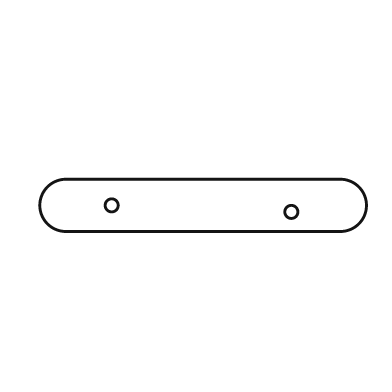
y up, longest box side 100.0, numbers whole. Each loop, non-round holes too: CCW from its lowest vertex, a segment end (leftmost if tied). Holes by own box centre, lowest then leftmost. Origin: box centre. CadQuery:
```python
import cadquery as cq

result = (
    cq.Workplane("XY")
    .moveTo(-42.0, -8.0)
    .lineTo(42.0, -8.0)
    .threePointArc((50.0, 0.0), (42.0, 8.0))
    .lineTo(-42.0, 8.0)
    .threePointArc((-50.0, 0.0), (-42.0, -8.0))
    .close()
    .moveTo(27.0, -2.0)
    .circle(2.0)
    .moveTo(-28.0, 0.0)
    .circle(2.0)
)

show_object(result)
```